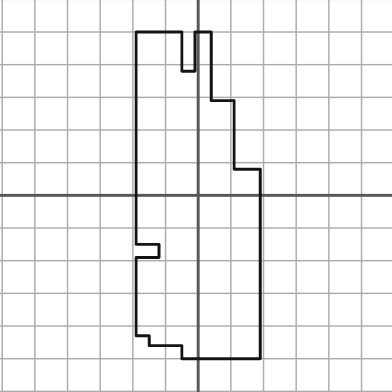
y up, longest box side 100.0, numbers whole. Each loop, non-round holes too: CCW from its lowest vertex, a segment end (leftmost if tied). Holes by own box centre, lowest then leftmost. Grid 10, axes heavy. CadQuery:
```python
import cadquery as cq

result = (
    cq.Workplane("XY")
    .moveTo(-5.0, -50.0)
    .lineTo(19.0, -50.0)
    .lineTo(19.0, 8.0)
    .lineTo(11.0, 8.0)
    .lineTo(11.0, 29.0)
    .lineTo(4.0, 29.0)
    .lineTo(4.0, 50.0)
    .lineTo(-1.0, 50.0)
    .lineTo(-1.0, 38.0)
    .lineTo(-5.0, 38.0)
    .lineTo(-5.0, 50.0)
    .lineTo(-19.0, 50.0)
    .lineTo(-19.0, -15.0)
    .lineTo(-12.0, -15.0)
    .lineTo(-12.0, -19.0)
    .lineTo(-19.0, -19.0)
    .lineTo(-19.0, -43.0)
    .lineTo(-15.0, -43.0)
    .lineTo(-15.0, -46.0)
    .lineTo(-5.0, -46.0)
    .close()
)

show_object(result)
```